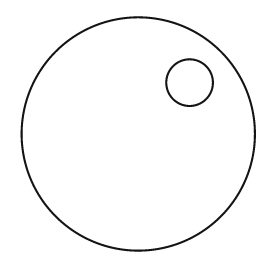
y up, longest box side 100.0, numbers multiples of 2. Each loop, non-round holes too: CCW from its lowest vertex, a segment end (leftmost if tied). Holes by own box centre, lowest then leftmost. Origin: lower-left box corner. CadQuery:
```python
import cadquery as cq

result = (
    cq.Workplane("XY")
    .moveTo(50.0, 50.0)
    .circle(50.0)
    .moveTo(72.0, 72.0)
    .circle(10.0)
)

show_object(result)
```